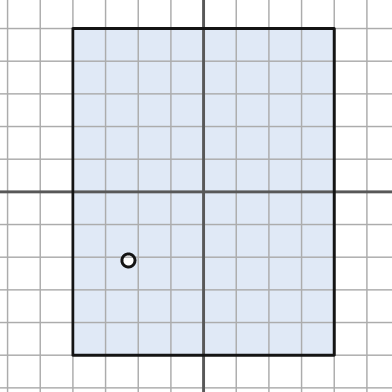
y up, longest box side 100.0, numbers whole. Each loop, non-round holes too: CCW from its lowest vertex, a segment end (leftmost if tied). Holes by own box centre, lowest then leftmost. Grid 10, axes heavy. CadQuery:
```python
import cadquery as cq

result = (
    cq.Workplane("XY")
    .moveTo(-40.0, -50.0)
    .lineTo(40.0, -50.0)
    .lineTo(40.0, 50.0)
    .lineTo(-40.0, 50.0)
    .close()
    .moveTo(-23.0, -21.0)
    .circle(2.0)
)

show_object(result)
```